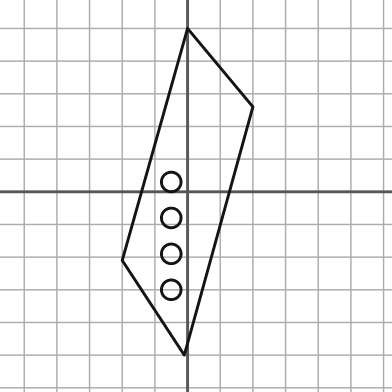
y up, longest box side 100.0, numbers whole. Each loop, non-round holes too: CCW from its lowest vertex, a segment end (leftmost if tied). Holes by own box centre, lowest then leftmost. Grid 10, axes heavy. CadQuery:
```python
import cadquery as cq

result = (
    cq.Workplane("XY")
    .moveTo(-1.0, -50.0)
    .lineTo(20.0, 26.0)
    .lineTo(0.0, 50.0)
    .lineTo(-20.0, -21.0)
    .close()
    .moveTo(-5.0, -30.0)
    .circle(3.0)
    .moveTo(-5.0, -19.0)
    .circle(3.0)
    .moveTo(-5.0, -8.0)
    .circle(3.0)
    .moveTo(-5.0, 3.0)
    .circle(3.0)
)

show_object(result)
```